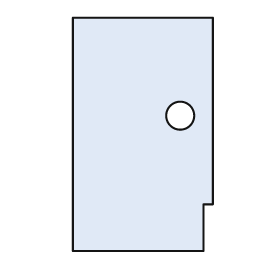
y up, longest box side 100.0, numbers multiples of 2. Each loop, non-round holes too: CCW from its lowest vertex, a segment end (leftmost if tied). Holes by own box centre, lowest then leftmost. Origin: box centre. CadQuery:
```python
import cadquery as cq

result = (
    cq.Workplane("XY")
    .moveTo(-30.0, -50.0)
    .lineTo(26.0, -50.0)
    .lineTo(26.0, -30.0)
    .lineTo(30.0, -30.0)
    .lineTo(30.0, 50.0)
    .lineTo(-30.0, 50.0)
    .close()
    .moveTo(16.0, 8.0)
    .circle(6.0)
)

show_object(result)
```